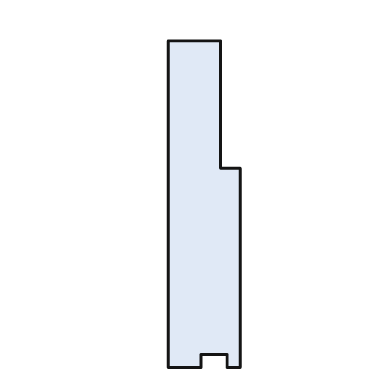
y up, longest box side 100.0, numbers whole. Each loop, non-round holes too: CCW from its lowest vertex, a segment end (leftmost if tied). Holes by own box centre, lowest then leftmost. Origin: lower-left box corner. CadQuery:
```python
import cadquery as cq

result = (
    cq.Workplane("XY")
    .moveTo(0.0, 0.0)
    .lineTo(10.0, 0.0)
    .lineTo(10.0, 4.0)
    .lineTo(18.0, 4.0)
    .lineTo(18.0, 0.0)
    .lineTo(22.0, 0.0)
    .lineTo(22.0, 61.0)
    .lineTo(16.0, 61.0)
    .lineTo(16.0, 100.0)
    .lineTo(0.0, 100.0)
    .close()
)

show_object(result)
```